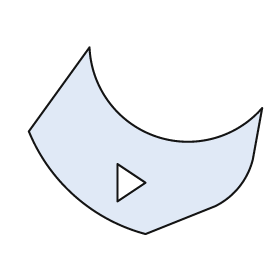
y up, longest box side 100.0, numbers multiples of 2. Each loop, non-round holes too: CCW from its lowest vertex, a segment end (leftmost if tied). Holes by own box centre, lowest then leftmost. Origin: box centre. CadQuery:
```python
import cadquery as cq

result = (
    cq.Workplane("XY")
    .moveTo(0.0, -40.0)
    .lineTo(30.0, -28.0)
    .threePointArc((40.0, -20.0), (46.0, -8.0))
    .lineTo(50.0, 14.0)
    .threePointArc((4.0, 2.0), (-24.0, 40.0))
    .lineTo(-50.0, 4.0)
    .threePointArc((-30.0, -24.0), (0.0, -40.0))
    .close()
    .moveTo(-12.0, -26.0)
    .lineTo(0.0, -18.0)
    .lineTo(-12.0, -10.0)
    .close()
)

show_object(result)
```